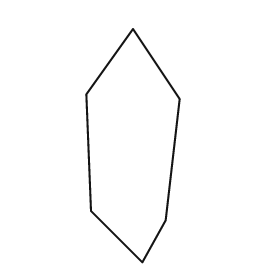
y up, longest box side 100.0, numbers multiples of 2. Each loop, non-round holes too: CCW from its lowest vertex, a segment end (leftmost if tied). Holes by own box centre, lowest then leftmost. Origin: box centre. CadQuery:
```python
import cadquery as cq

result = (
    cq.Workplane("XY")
    .moveTo(4.0, -50.0)
    .lineTo(14.0, -32.0)
    .lineTo(20.0, 20.0)
    .lineTo(0.0, 50.0)
    .lineTo(-20.0, 22.0)
    .lineTo(-18.0, -28.0)
    .close()
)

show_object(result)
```